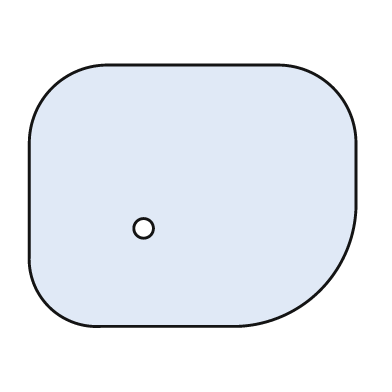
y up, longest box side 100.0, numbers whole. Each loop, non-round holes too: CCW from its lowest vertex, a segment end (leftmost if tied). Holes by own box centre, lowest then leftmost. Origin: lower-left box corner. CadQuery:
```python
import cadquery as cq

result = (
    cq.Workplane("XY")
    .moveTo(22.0, 0.0)
    .lineTo(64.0, 0.0)
    .threePointArc((89.0, 11.0), (100.0, 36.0))
    .lineTo(100.0, 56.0)
    .threePointArc((93.0, 73.0), (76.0, 80.0))
    .lineTo(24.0, 80.0)
    .threePointArc((7.0, 73.0), (0.0, 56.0))
    .lineTo(0.0, 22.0)
    .threePointArc((6.0, 6.0), (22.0, 0.0))
    .close()
    .moveTo(35.0, 30.0)
    .circle(3.0)
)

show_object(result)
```